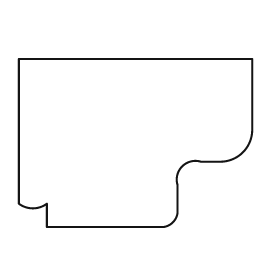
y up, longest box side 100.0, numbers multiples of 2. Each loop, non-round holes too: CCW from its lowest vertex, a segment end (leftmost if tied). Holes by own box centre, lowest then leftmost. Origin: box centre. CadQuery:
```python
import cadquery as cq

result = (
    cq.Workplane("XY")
    .moveTo(-38.0, -36.0)
    .lineTo(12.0, -36.0)
    .threePointArc((16.0, -34.0), (18.0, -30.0))
    .lineTo(18.0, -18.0)
    .threePointArc((20.0, -10.0), (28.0, -8.0))
    .lineTo(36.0, -8.0)
    .threePointArc((46.0, -4.0), (50.0, 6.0))
    .lineTo(50.0, 36.0)
    .lineTo(-50.0, 36.0)
    .lineTo(-50.0, -26.0)
    .threePointArc((-44.0, -28.0), (-38.0, -26.0))
    .close()
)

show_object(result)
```